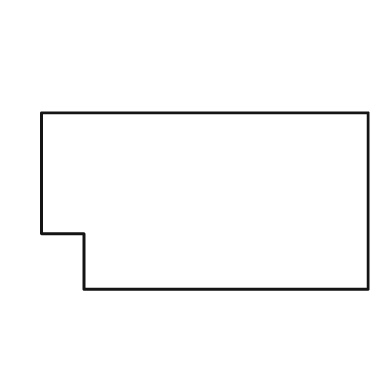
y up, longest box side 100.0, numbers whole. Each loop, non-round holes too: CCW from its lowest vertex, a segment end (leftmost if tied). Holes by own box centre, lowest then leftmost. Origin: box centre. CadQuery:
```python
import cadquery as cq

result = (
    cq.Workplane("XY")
    .moveTo(-37.0, -27.0)
    .lineTo(50.0, -27.0)
    .lineTo(50.0, 27.0)
    .lineTo(-50.0, 27.0)
    .lineTo(-50.0, -10.0)
    .lineTo(-37.0, -10.0)
    .close()
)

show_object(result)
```